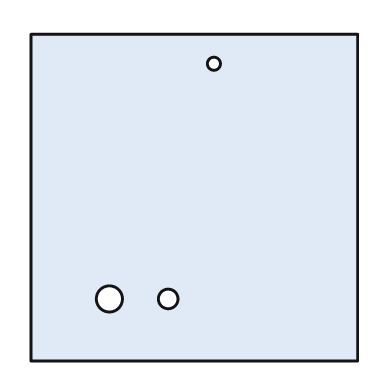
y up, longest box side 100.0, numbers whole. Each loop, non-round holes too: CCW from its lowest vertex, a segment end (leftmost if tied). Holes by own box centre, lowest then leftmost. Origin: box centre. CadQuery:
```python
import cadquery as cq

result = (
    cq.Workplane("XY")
    .moveTo(-50.0, -50.0)
    .lineTo(50.0, -50.0)
    .lineTo(50.0, 50.0)
    .lineTo(-50.0, 50.0)
    .close()
    .moveTo(-26.0, -31.0)
    .circle(4.0)
    .moveTo(-8.0, -31.0)
    .circle(3.0)
    .moveTo(6.0, 41.0)
    .circle(2.0)
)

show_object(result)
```